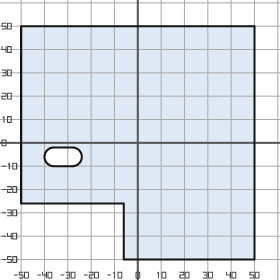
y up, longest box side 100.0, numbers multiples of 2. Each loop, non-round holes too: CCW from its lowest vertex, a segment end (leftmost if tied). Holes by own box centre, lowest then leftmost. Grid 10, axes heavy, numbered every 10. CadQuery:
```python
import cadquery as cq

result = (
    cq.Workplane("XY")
    .moveTo(-6.0, -50.0)
    .lineTo(50.0, -50.0)
    .lineTo(50.0, 50.0)
    .lineTo(-50.0, 50.0)
    .lineTo(-50.0, -26.0)
    .lineTo(-6.0, -26.0)
    .close()
    .moveTo(-36.0, -10.0)
    .lineTo(-28.0, -10.0)
    .threePointArc((-24.0, -6.0), (-28.0, -2.0))
    .lineTo(-36.0, -2.0)
    .threePointArc((-40.0, -6.0), (-36.0, -10.0))
    .close()
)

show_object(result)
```